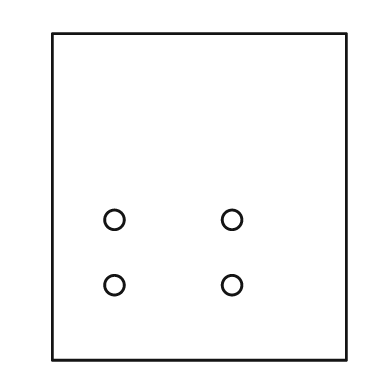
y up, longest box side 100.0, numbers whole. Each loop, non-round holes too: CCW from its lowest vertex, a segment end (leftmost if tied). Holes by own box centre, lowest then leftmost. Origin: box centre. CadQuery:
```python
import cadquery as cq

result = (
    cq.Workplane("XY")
    .moveTo(-45.0, -50.0)
    .lineTo(45.0, -50.0)
    .lineTo(45.0, 50.0)
    .lineTo(-45.0, 50.0)
    .close()
    .moveTo(-26.0, -27.0)
    .circle(3.0)
    .moveTo(10.0, -27.0)
    .circle(3.0)
    .moveTo(-26.0, -7.0)
    .circle(3.0)
    .moveTo(10.0, -7.0)
    .circle(3.0)
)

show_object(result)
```